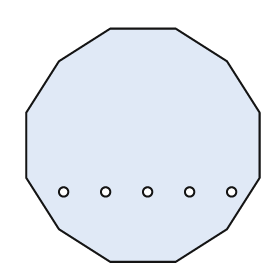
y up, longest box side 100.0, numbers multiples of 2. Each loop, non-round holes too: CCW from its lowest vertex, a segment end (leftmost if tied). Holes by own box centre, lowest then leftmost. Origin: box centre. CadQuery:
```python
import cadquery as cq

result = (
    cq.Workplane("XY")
    .moveTo(-14.0, -50.0)
    .lineTo(14.0, -50.0)
    .lineTo(36.0, -36.0)
    .lineTo(50.0, -14.0)
    .lineTo(50.0, 14.0)
    .lineTo(36.0, 36.0)
    .lineTo(14.0, 50.0)
    .lineTo(-14.0, 50.0)
    .lineTo(-36.0, 36.0)
    .lineTo(-50.0, 14.0)
    .lineTo(-50.0, -14.0)
    .lineTo(-36.0, -36.0)
    .close()
    .moveTo(-34.0, -20.0)
    .circle(2.0)
    .moveTo(-16.0, -20.0)
    .circle(2.0)
    .moveTo(2.0, -20.0)
    .circle(2.0)
    .moveTo(20.0, -20.0)
    .circle(2.0)
    .moveTo(38.0, -20.0)
    .circle(2.0)
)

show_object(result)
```